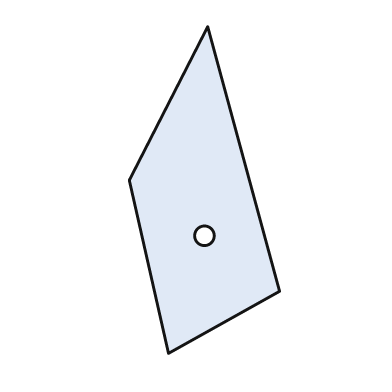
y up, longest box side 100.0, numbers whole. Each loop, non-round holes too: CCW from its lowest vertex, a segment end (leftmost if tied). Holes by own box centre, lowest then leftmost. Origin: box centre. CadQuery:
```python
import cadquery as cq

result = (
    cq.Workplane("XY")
    .moveTo(-11.0, -50.0)
    .lineTo(23.0, -31.0)
    .lineTo(1.0, 50.0)
    .lineTo(-23.0, 3.0)
    .close()
    .moveTo(0.0, -14.0)
    .circle(3.0)
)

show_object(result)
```